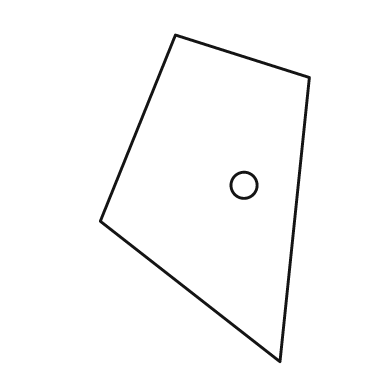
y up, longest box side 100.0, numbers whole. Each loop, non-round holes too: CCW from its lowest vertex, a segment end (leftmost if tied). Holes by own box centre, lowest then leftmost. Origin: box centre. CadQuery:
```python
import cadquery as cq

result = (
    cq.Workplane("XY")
    .moveTo(23.0, -50.0)
    .lineTo(32.0, 37.0)
    .lineTo(-9.0, 50.0)
    .lineTo(-32.0, -7.0)
    .close()
    .moveTo(12.0, 4.0)
    .circle(4.0)
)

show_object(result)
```